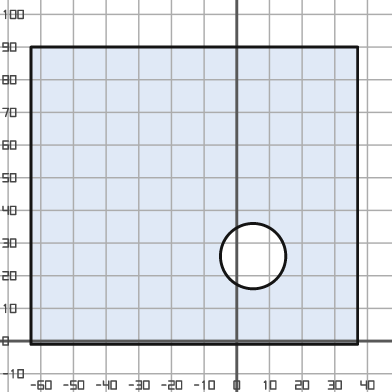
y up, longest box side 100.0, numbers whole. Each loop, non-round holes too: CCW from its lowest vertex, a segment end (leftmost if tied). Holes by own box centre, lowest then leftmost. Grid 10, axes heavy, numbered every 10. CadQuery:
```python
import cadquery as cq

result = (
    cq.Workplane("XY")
    .moveTo(-63.0, -1.0)
    .lineTo(37.0, -1.0)
    .lineTo(37.0, 90.0)
    .lineTo(-63.0, 90.0)
    .close()
    .moveTo(5.0, 26.0)
    .circle(10.0)
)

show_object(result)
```